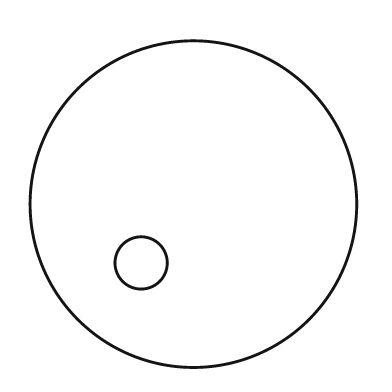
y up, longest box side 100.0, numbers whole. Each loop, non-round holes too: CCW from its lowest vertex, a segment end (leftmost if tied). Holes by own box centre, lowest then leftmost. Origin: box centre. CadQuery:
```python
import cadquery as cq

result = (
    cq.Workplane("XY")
    .moveTo(0.0, 0.0)
    .circle(50.0)
    .moveTo(-16.0, -18.0)
    .circle(8.0)
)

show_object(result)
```